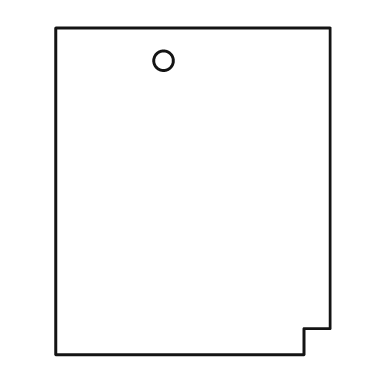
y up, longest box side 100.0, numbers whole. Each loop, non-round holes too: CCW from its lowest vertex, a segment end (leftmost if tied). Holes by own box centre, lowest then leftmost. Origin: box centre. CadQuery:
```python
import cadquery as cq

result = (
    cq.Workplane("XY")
    .moveTo(-42.0, -50.0)
    .lineTo(34.0, -50.0)
    .lineTo(34.0, -42.0)
    .lineTo(42.0, -42.0)
    .lineTo(42.0, 50.0)
    .lineTo(-42.0, 50.0)
    .close()
    .moveTo(-9.0, 40.0)
    .circle(3.0)
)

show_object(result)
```